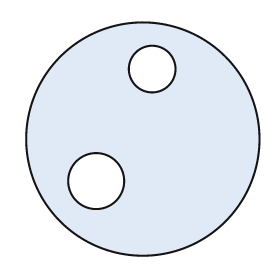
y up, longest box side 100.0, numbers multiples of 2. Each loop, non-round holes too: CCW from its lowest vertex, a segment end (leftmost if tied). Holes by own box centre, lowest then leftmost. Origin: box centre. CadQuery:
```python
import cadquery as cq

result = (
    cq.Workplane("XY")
    .moveTo(0.0, 0.0)
    .circle(50.0)
    .moveTo(-20.0, -18.0)
    .circle(12.0)
    .moveTo(4.0, 30.0)
    .circle(10.0)
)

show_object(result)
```